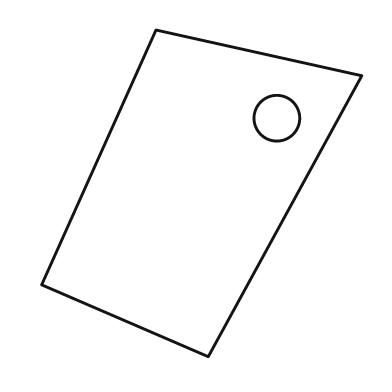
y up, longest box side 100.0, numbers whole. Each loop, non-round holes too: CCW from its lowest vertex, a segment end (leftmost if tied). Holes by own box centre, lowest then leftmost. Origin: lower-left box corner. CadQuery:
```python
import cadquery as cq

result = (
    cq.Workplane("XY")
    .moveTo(51.0, 0.0)
    .lineTo(98.0, 86.0)
    .lineTo(35.0, 100.0)
    .lineTo(0.0, 22.0)
    .close()
    .moveTo(72.0, 73.0)
    .circle(7.0)
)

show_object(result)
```